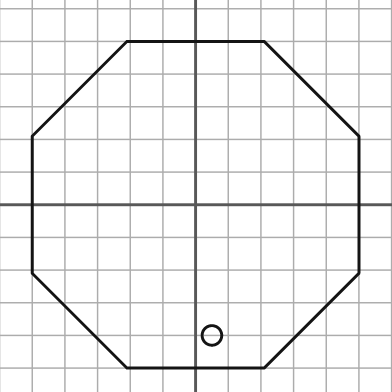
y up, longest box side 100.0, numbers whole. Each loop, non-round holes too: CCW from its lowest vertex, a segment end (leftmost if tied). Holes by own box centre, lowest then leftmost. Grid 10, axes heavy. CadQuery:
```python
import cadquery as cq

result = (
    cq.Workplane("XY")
    .moveTo(-21.0, -50.0)
    .lineTo(21.0, -50.0)
    .lineTo(50.0, -21.0)
    .lineTo(50.0, 21.0)
    .lineTo(21.0, 50.0)
    .lineTo(-21.0, 50.0)
    .lineTo(-50.0, 21.0)
    .lineTo(-50.0, -21.0)
    .close()
    .moveTo(5.0, -40.0)
    .circle(3.0)
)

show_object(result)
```